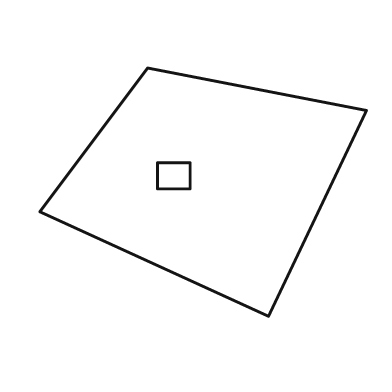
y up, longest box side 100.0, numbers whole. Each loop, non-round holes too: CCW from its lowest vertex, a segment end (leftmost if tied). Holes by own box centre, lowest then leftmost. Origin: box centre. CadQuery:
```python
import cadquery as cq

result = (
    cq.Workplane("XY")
    .moveTo(20.0, -38.0)
    .lineTo(50.0, 25.0)
    .lineTo(-17.0, 38.0)
    .lineTo(-50.0, -6.0)
    .close()
    .moveTo(-14.0, 1.0)
    .lineTo(-4.0, 1.0)
    .lineTo(-4.0, 9.0)
    .lineTo(-14.0, 9.0)
    .close()
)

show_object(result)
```